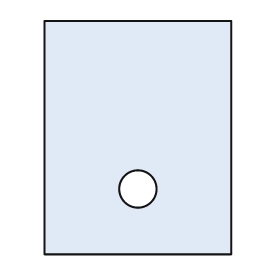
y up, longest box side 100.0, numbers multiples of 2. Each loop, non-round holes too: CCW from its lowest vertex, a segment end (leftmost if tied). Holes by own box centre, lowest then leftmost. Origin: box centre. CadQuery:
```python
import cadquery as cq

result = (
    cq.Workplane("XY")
    .moveTo(-40.0, -50.0)
    .lineTo(40.0, -50.0)
    .lineTo(40.0, 50.0)
    .lineTo(-40.0, 50.0)
    .close()
    .moveTo(0.0, -22.0)
    .circle(8.0)
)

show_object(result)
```